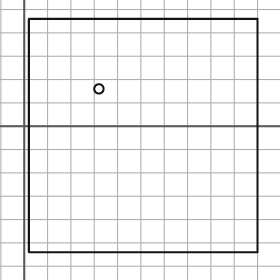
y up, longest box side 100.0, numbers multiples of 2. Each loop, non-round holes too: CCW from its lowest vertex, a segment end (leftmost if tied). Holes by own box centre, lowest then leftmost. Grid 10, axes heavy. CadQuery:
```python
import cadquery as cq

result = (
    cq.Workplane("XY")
    .moveTo(2.0, -54.0)
    .lineTo(100.0, -54.0)
    .lineTo(100.0, 46.0)
    .lineTo(2.0, 46.0)
    .close()
    .moveTo(32.0, 16.0)
    .circle(2.0)
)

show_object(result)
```